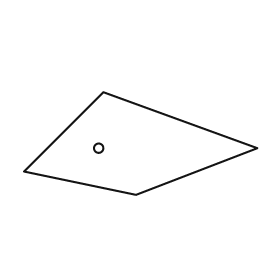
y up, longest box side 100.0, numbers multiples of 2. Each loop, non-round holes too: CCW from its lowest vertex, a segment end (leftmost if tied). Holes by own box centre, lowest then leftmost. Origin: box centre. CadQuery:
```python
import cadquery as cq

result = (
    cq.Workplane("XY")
    .moveTo(-2.0, -22.0)
    .lineTo(50.0, -2.0)
    .lineTo(-16.0, 22.0)
    .lineTo(-50.0, -12.0)
    .close()
    .moveTo(-18.0, -2.0)
    .circle(2.0)
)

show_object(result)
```